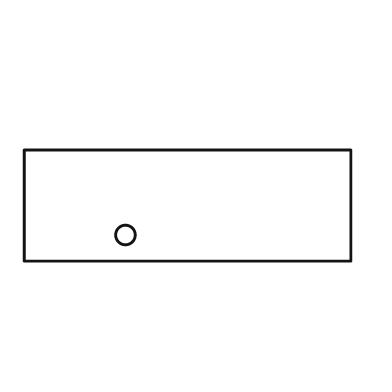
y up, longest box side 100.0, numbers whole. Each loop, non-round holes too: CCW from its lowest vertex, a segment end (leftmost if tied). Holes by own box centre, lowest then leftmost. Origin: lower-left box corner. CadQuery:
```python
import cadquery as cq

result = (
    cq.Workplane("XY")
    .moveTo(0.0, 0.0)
    .lineTo(100.0, 0.0)
    .lineTo(100.0, 34.0)
    .lineTo(0.0, 34.0)
    .close()
    .moveTo(31.0, 8.0)
    .circle(3.0)
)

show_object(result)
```